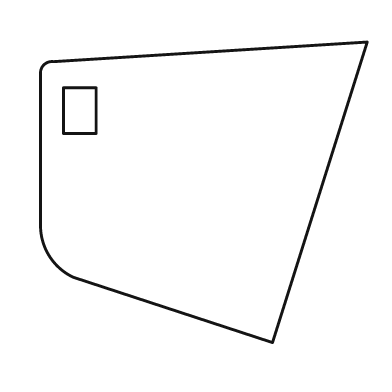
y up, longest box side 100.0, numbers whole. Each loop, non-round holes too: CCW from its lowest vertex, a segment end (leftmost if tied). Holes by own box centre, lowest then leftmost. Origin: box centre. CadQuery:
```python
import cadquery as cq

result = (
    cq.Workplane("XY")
    .moveTo(21.0, -46.0)
    .lineTo(50.0, 46.0)
    .lineTo(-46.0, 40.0)
    .threePointArc((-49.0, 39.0), (-50.0, 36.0))
    .lineTo(-50.0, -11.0)
    .threePointArc((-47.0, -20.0), (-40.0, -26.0))
    .close()
    .moveTo(-43.0, 18.0)
    .lineTo(-33.0, 18.0)
    .lineTo(-33.0, 32.0)
    .lineTo(-43.0, 32.0)
    .close()
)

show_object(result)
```